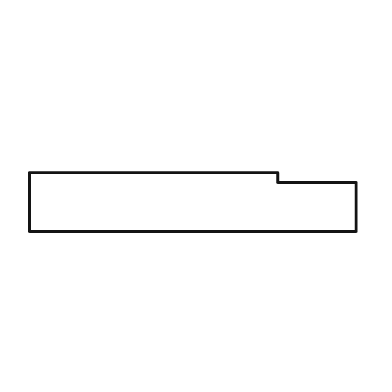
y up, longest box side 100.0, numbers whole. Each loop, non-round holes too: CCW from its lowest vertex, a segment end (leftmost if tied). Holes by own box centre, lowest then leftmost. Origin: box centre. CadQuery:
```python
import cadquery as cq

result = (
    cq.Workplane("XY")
    .moveTo(-50.0, -9.0)
    .lineTo(50.0, -9.0)
    .lineTo(50.0, 6.0)
    .lineTo(26.0, 6.0)
    .lineTo(26.0, 9.0)
    .lineTo(-50.0, 9.0)
    .close()
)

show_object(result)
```